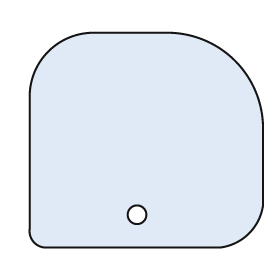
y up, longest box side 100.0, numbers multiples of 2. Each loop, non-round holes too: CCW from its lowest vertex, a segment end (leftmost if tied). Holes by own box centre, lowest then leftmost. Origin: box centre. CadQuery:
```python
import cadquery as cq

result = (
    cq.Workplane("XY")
    .moveTo(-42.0, -46.0)
    .lineTo(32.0, -46.0)
    .threePointArc((44.0, -40.0), (50.0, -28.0))
    .lineTo(50.0, 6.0)
    .threePointArc((38.0, 34.0), (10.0, 46.0))
    .lineTo(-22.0, 46.0)
    .threePointArc((-42.0, 38.0), (-50.0, 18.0))
    .lineTo(-50.0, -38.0)
    .threePointArc((-48.0, -44.0), (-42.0, -46.0))
    .close()
    .moveTo(-4.0, -32.0)
    .circle(4.0)
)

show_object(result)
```